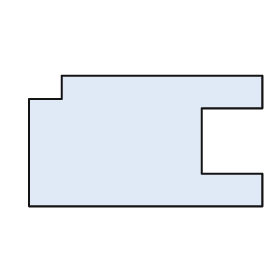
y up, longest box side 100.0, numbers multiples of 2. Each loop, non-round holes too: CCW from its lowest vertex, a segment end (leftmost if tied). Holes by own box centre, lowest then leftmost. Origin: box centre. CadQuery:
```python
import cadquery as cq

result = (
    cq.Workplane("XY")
    .moveTo(-50.0, -28.0)
    .lineTo(50.0, -28.0)
    .lineTo(50.0, -14.0)
    .lineTo(24.0, -14.0)
    .lineTo(24.0, 14.0)
    .lineTo(50.0, 14.0)
    .lineTo(50.0, 28.0)
    .lineTo(-36.0, 28.0)
    .lineTo(-36.0, 18.0)
    .lineTo(-50.0, 18.0)
    .close()
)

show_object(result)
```